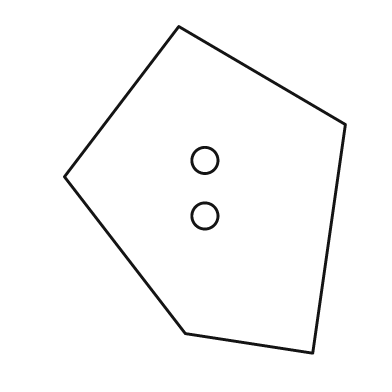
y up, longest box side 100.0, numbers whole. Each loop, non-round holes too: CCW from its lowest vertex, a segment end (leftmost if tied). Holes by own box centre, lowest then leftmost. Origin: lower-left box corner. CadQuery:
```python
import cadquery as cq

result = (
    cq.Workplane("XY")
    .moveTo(76.0, 0.0)
    .lineTo(86.0, 70.0)
    .lineTo(35.0, 100.0)
    .lineTo(0.0, 54.0)
    .lineTo(37.0, 6.0)
    .close()
    .moveTo(43.0, 42.0)
    .circle(4.0)
    .moveTo(43.0, 59.0)
    .circle(4.0)
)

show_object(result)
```